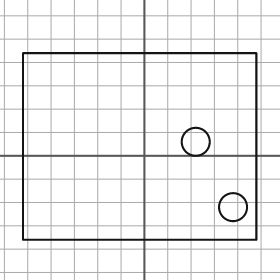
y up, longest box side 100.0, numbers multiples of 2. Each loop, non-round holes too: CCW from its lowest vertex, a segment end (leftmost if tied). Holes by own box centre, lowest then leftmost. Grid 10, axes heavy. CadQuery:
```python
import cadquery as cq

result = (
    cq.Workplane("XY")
    .moveTo(-52.0, -36.0)
    .lineTo(48.0, -36.0)
    .lineTo(48.0, 44.0)
    .lineTo(-52.0, 44.0)
    .close()
    .moveTo(38.0, -22.0)
    .circle(6.0)
    .moveTo(22.0, 6.0)
    .circle(6.0)
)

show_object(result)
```